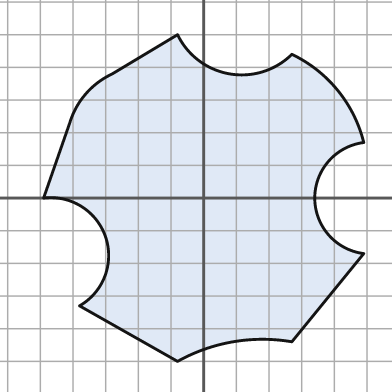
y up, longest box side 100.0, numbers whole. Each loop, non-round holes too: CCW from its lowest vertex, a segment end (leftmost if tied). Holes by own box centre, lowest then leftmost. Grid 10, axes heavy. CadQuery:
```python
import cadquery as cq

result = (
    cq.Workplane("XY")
    .moveTo(-8.0, -50.0)
    .threePointArc((9.0, -44.0), (27.0, -44.0))
    .lineTo(49.0, -17.0)
    .threePointArc((34.0, 0.0), (49.0, 17.0))
    .threePointArc((41.0, 33.0), (27.0, 44.0))
    .threePointArc((8.0, 38.0), (-8.0, 50.0))
    .lineTo(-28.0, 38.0)
    .threePointArc((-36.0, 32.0), (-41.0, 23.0))
    .lineTo(-49.0, 0.0)
    .threePointArc((-30.0, -12.0), (-38.0, -33.0))
    .close()
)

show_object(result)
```